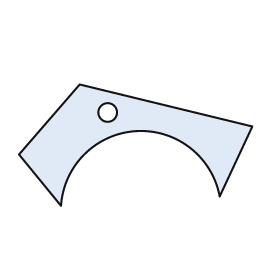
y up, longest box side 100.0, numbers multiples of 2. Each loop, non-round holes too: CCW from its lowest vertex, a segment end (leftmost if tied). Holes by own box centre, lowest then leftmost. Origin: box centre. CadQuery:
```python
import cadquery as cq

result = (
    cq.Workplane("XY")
    .moveTo(-32.0, -26.0)
    .threePointArc((0.0, 6.0), (36.0, -22.0))
    .lineTo(50.0, 8.0)
    .lineTo(-24.0, 26.0)
    .lineTo(-50.0, -4.0)
    .close()
    .moveTo(-12.0, 14.0)
    .circle(4.0)
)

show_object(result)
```